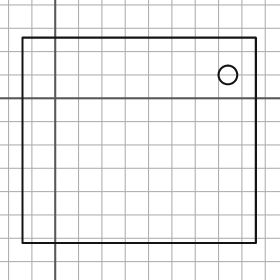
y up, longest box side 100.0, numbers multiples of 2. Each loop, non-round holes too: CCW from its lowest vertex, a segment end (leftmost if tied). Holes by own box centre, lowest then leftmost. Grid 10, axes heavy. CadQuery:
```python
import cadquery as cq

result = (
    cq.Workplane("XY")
    .moveTo(-14.0, -62.0)
    .lineTo(86.0, -62.0)
    .lineTo(86.0, 26.0)
    .lineTo(-14.0, 26.0)
    .close()
    .moveTo(74.0, 10.0)
    .circle(4.0)
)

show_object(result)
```